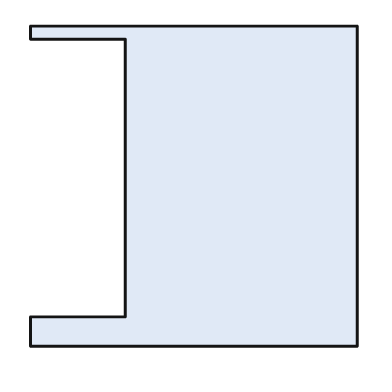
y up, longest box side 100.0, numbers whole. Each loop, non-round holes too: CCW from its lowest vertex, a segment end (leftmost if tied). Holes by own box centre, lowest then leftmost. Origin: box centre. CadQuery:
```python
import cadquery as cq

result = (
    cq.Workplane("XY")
    .moveTo(-50.0, -49.0)
    .lineTo(50.0, -49.0)
    .lineTo(50.0, 49.0)
    .lineTo(-50.0, 49.0)
    .lineTo(-50.0, 45.0)
    .lineTo(-21.0, 45.0)
    .lineTo(-21.0, -40.0)
    .lineTo(-50.0, -40.0)
    .close()
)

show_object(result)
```